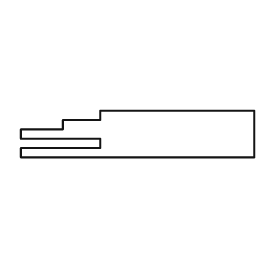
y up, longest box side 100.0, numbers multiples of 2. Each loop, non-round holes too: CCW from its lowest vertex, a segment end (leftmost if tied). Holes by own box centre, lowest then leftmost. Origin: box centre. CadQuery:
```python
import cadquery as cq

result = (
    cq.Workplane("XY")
    .moveTo(-50.0, -10.0)
    .lineTo(50.0, -10.0)
    .lineTo(50.0, 10.0)
    .lineTo(-16.0, 10.0)
    .lineTo(-16.0, 6.0)
    .lineTo(-32.0, 6.0)
    .lineTo(-32.0, 2.0)
    .lineTo(-50.0, 2.0)
    .lineTo(-50.0, -2.0)
    .lineTo(-16.0, -2.0)
    .lineTo(-16.0, -6.0)
    .lineTo(-50.0, -6.0)
    .close()
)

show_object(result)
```